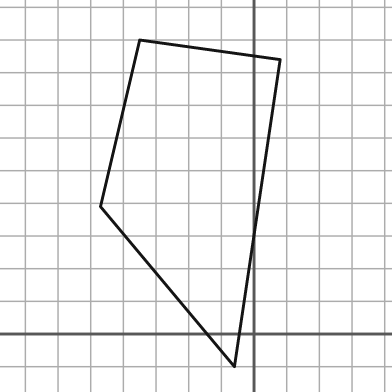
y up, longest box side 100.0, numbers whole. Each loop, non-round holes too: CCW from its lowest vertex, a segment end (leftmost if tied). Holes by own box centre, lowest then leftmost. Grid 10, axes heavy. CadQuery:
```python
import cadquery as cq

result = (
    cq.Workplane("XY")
    .moveTo(-6.0, -10.0)
    .lineTo(8.0, 84.0)
    .lineTo(-35.0, 90.0)
    .lineTo(-47.0, 39.0)
    .close()
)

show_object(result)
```